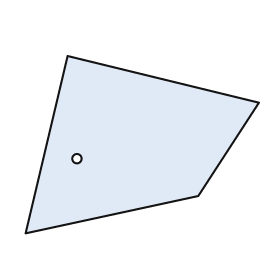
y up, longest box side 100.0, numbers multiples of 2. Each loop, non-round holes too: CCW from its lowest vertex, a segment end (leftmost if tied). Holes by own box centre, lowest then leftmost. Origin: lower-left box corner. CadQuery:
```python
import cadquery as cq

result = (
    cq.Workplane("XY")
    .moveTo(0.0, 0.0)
    .lineTo(74.0, 16.0)
    .lineTo(100.0, 56.0)
    .lineTo(18.0, 76.0)
    .close()
    .moveTo(22.0, 32.0)
    .circle(2.0)
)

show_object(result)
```